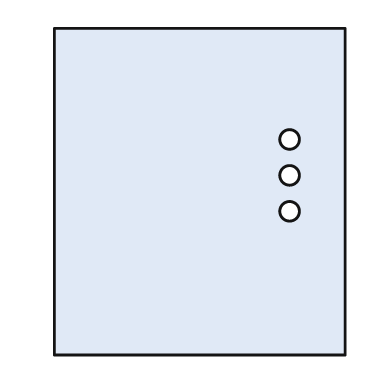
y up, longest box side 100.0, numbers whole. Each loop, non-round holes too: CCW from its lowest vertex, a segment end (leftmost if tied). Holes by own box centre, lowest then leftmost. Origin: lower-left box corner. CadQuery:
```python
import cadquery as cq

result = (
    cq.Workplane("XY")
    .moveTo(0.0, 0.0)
    .lineTo(89.0, 0.0)
    .lineTo(89.0, 100.0)
    .lineTo(0.0, 100.0)
    .close()
    .moveTo(72.0, 44.0)
    .circle(3.0)
    .moveTo(72.0, 55.0)
    .circle(3.0)
    .moveTo(72.0, 66.0)
    .circle(3.0)
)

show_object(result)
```